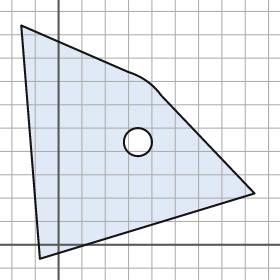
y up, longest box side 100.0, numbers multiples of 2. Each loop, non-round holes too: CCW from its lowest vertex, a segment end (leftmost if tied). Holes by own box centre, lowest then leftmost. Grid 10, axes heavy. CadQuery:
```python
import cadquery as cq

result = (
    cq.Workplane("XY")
    .moveTo(-8.0, -6.0)
    .lineTo(84.0, 22.0)
    .lineTo(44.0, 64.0)
    .threePointArc((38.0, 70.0), (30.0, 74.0))
    .lineTo(-16.0, 94.0)
    .close()
    .moveTo(34.0, 44.0)
    .circle(6.0)
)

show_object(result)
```